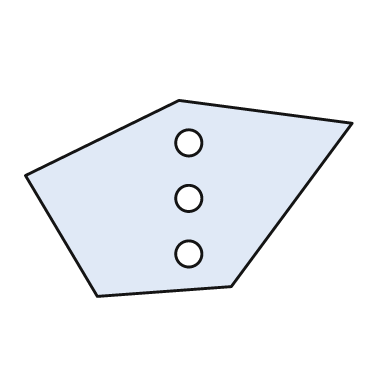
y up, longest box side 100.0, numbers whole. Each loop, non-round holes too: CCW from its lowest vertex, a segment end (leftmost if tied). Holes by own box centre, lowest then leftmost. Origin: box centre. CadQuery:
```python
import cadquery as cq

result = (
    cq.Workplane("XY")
    .moveTo(-28.0, -30.0)
    .lineTo(13.0, -27.0)
    .lineTo(50.0, 23.0)
    .lineTo(-3.0, 30.0)
    .lineTo(-50.0, 7.0)
    .close()
    .moveTo(0.0, -17.0)
    .circle(4.0)
    .moveTo(0.0, 0.0)
    .circle(4.0)
    .moveTo(0.0, 17.0)
    .circle(4.0)
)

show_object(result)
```